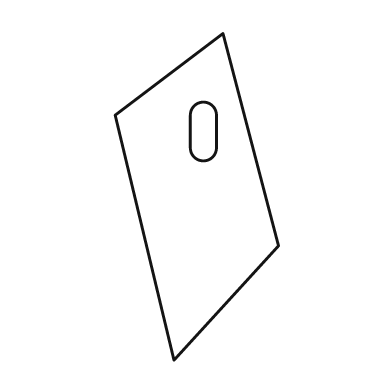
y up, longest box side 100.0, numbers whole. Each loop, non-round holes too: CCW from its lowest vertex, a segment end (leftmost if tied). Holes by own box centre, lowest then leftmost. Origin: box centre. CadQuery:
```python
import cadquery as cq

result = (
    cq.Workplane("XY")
    .moveTo(-7.0, -50.0)
    .lineTo(25.0, -15.0)
    .lineTo(8.0, 50.0)
    .lineTo(-25.0, 25.0)
    .close()
    .moveTo(-2.0, 15.0)
    .threePointArc((2.0, 11.0), (6.0, 15.0))
    .lineTo(6.0, 25.0)
    .threePointArc((2.0, 29.0), (-2.0, 25.0))
    .close()
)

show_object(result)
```